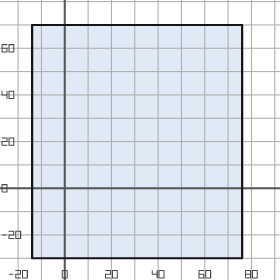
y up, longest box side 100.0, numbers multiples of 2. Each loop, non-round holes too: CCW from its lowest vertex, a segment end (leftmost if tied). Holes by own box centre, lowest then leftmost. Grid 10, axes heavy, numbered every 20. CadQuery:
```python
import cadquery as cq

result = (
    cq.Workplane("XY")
    .moveTo(-14.0, -30.0)
    .lineTo(76.0, -30.0)
    .lineTo(76.0, 70.0)
    .lineTo(-14.0, 70.0)
    .close()
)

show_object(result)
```